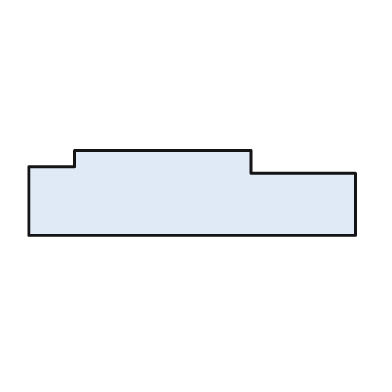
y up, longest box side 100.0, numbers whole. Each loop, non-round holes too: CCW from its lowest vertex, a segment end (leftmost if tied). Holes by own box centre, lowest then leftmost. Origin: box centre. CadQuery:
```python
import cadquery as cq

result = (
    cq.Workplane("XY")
    .moveTo(-50.0, -13.0)
    .lineTo(50.0, -13.0)
    .lineTo(50.0, 6.0)
    .lineTo(18.0, 6.0)
    .lineTo(18.0, 13.0)
    .lineTo(-36.0, 13.0)
    .lineTo(-36.0, 8.0)
    .lineTo(-50.0, 8.0)
    .close()
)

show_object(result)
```